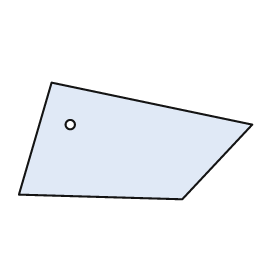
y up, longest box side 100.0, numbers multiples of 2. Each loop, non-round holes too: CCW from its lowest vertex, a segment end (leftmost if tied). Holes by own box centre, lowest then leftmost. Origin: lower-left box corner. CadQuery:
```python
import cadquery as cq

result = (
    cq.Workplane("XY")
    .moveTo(70.0, 0.0)
    .lineTo(100.0, 32.0)
    .lineTo(14.0, 50.0)
    .lineTo(0.0, 2.0)
    .close()
    .moveTo(22.0, 32.0)
    .circle(2.0)
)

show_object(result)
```